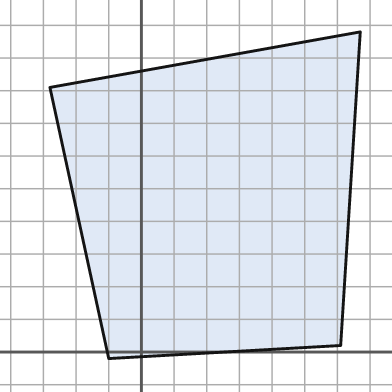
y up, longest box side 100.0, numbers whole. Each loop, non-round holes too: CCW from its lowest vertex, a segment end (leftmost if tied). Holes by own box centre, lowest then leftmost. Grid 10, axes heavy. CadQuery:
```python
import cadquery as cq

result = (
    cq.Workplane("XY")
    .moveTo(-10.0, -2.0)
    .lineTo(61.0, 2.0)
    .lineTo(67.0, 98.0)
    .lineTo(-28.0, 81.0)
    .close()
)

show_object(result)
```